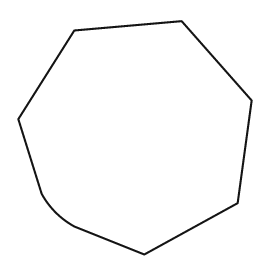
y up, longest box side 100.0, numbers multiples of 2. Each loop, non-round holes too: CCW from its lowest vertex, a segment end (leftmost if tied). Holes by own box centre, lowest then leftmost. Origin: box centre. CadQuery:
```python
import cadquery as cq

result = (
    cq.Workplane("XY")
    .moveTo(4.0, -50.0)
    .lineTo(44.0, -28.0)
    .lineTo(50.0, 16.0)
    .lineTo(20.0, 50.0)
    .lineTo(-26.0, 46.0)
    .lineTo(-50.0, 8.0)
    .lineTo(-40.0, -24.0)
    .threePointArc((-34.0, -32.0), (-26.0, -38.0))
    .close()
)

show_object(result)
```